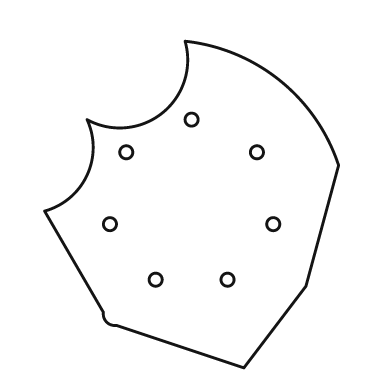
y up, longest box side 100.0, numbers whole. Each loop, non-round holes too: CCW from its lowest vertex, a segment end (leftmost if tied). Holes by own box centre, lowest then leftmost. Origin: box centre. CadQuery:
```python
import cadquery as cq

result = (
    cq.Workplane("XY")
    .moveTo(16.0, -50.0)
    .lineTo(35.0, -25.0)
    .lineTo(45.0, 12.0)
    .threePointArc((27.0, 38.0), (-2.0, 50.0))
    .threePointArc((-9.0, 28.0), (-32.0, 26.0))
    .threePointArc((-32.0, 9.0), (-45.0, -2.0))
    .lineTo(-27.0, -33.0)
    .threePointArc((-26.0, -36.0), (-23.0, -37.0))
    .close()
    .moveTo(-11.0, -23.0)
    .circle(2.0)
    .moveTo(11.0, -23.0)
    .circle(2.0)
    .moveTo(-25.0, -6.0)
    .circle(2.0)
    .moveTo(25.0, -6.0)
    .circle(2.0)
    .moveTo(-20.0, 16.0)
    .circle(2.0)
    .moveTo(20.0, 16.0)
    .circle(2.0)
    .moveTo(0.0, 26.0)
    .circle(2.0)
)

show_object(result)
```